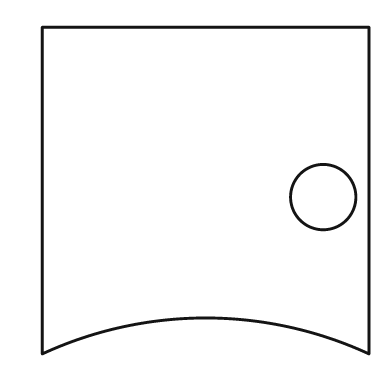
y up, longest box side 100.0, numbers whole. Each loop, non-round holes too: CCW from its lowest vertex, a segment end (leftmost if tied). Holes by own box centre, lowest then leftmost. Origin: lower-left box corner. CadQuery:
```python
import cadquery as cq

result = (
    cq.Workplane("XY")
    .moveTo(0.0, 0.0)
    .threePointArc((50.0, 11.0), (100.0, 0.0))
    .lineTo(100.0, 100.0)
    .lineTo(0.0, 100.0)
    .close()
    .moveTo(86.0, 48.0)
    .circle(10.0)
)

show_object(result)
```